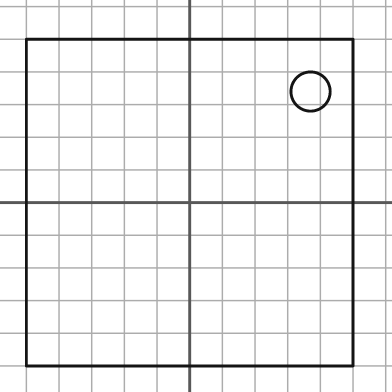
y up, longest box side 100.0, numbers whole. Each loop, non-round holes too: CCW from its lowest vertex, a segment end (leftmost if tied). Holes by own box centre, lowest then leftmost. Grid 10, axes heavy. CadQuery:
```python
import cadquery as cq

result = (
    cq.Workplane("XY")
    .moveTo(-50.0, -50.0)
    .lineTo(50.0, -50.0)
    .lineTo(50.0, 50.0)
    .lineTo(-50.0, 50.0)
    .close()
    .moveTo(37.0, 34.0)
    .circle(6.0)
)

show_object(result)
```